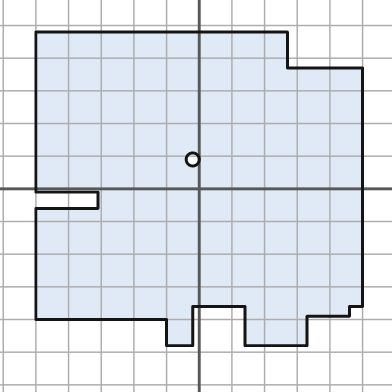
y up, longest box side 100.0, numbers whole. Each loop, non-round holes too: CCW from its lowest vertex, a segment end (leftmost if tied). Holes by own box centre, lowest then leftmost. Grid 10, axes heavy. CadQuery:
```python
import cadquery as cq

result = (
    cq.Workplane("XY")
    .moveTo(-10.0, -48.0)
    .lineTo(-2.0, -48.0)
    .lineTo(-2.0, -36.0)
    .lineTo(14.0, -36.0)
    .lineTo(14.0, -48.0)
    .lineTo(33.0, -48.0)
    .lineTo(33.0, -39.0)
    .lineTo(46.0, -39.0)
    .lineTo(46.0, -36.0)
    .lineTo(50.0, -36.0)
    .lineTo(50.0, 37.0)
    .lineTo(27.0, 37.0)
    .lineTo(27.0, 48.0)
    .lineTo(-50.0, 48.0)
    .lineTo(-50.0, -1.0)
    .lineTo(-31.0, -1.0)
    .lineTo(-31.0, -6.0)
    .lineTo(-50.0, -6.0)
    .lineTo(-50.0, -40.0)
    .lineTo(-10.0, -40.0)
    .close()
    .moveTo(-2.0, 9.0)
    .circle(2.0)
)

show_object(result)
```